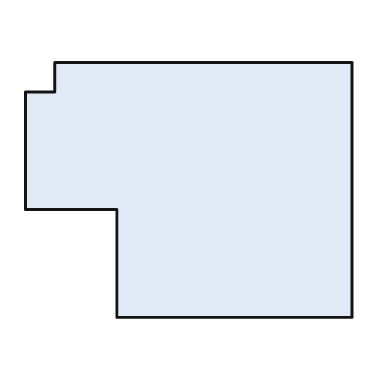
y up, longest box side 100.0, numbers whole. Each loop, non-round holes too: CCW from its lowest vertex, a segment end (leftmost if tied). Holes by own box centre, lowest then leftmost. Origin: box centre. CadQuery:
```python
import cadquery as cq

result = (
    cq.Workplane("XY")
    .moveTo(-22.0, -39.0)
    .lineTo(50.0, -39.0)
    .lineTo(50.0, 39.0)
    .lineTo(-41.0, 39.0)
    .lineTo(-41.0, 30.0)
    .lineTo(-50.0, 30.0)
    .lineTo(-50.0, -6.0)
    .lineTo(-22.0, -6.0)
    .close()
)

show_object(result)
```